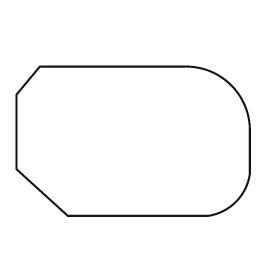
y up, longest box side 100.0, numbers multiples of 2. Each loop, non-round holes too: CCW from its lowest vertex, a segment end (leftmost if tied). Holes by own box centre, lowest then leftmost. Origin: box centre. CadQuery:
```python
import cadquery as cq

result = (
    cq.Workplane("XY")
    .moveTo(-28.0, -32.0)
    .lineTo(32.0, -32.0)
    .threePointArc((44.0, -26.0), (50.0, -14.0))
    .lineTo(50.0, 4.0)
    .threePointArc((42.0, 24.0), (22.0, 32.0))
    .lineTo(-40.0, 32.0)
    .lineTo(-50.0, 20.0)
    .lineTo(-50.0, -12.0)
    .close()
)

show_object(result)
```